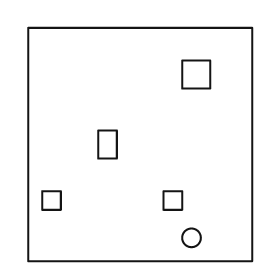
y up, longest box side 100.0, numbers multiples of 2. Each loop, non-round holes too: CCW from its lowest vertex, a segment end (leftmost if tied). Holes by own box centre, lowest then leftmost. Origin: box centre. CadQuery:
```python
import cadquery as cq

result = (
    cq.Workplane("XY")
    .moveTo(-48.0, -50.0)
    .lineTo(48.0, -50.0)
    .lineTo(48.0, 50.0)
    .lineTo(-48.0, 50.0)
    .close()
    .moveTo(22.0, -40.0)
    .circle(4.0)
    .moveTo(-42.0, -28.0)
    .lineTo(-34.0, -28.0)
    .lineTo(-34.0, -20.0)
    .lineTo(-42.0, -20.0)
    .close()
    .moveTo(10.0, -28.0)
    .lineTo(18.0, -28.0)
    .lineTo(18.0, -20.0)
    .lineTo(10.0, -20.0)
    .close()
    .moveTo(-18.0, -6.0)
    .lineTo(-10.0, -6.0)
    .lineTo(-10.0, 6.0)
    .lineTo(-18.0, 6.0)
    .close()
    .moveTo(18.0, 24.0)
    .lineTo(30.0, 24.0)
    .lineTo(30.0, 36.0)
    .lineTo(18.0, 36.0)
    .close()
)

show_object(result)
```